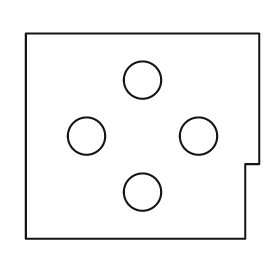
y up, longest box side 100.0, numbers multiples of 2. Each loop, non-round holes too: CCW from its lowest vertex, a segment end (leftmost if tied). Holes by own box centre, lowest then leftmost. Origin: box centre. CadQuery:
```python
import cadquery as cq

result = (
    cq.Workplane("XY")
    .moveTo(-50.0, -44.0)
    .lineTo(44.0, -44.0)
    .lineTo(44.0, -12.0)
    .lineTo(50.0, -12.0)
    .lineTo(50.0, 44.0)
    .lineTo(-50.0, 44.0)
    .close()
    .moveTo(0.0, -24.0)
    .circle(8.0)
    .moveTo(-24.0, 0.0)
    .circle(8.0)
    .moveTo(24.0, 0.0)
    .circle(8.0)
    .moveTo(0.0, 24.0)
    .circle(8.0)
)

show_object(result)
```